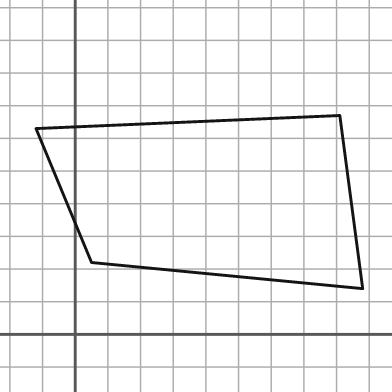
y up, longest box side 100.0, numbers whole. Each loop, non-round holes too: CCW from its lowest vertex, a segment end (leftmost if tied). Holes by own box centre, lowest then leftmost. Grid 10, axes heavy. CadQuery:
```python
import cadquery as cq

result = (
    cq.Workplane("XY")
    .moveTo(88.0, 14.0)
    .lineTo(81.0, 67.0)
    .lineTo(-12.0, 63.0)
    .lineTo(5.0, 22.0)
    .close()
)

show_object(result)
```